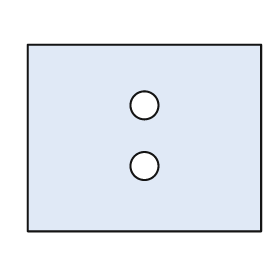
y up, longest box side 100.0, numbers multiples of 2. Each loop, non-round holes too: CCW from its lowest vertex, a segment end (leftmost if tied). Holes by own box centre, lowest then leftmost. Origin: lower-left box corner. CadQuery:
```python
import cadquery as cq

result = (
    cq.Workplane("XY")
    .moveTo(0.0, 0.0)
    .lineTo(100.0, 0.0)
    .lineTo(100.0, 80.0)
    .lineTo(0.0, 80.0)
    .close()
    .moveTo(50.0, 28.0)
    .circle(6.0)
    .moveTo(50.0, 54.0)
    .circle(6.0)
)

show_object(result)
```